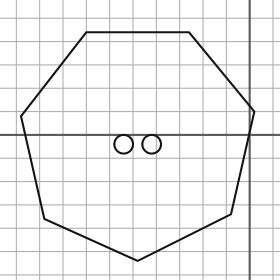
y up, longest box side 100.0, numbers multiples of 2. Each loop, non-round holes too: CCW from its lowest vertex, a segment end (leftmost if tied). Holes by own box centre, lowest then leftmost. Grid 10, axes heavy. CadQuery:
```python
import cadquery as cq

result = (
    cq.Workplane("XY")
    .moveTo(-48.0, -54.0)
    .lineTo(-8.0, -34.0)
    .lineTo(2.0, 10.0)
    .lineTo(-26.0, 44.0)
    .lineTo(-70.0, 44.0)
    .lineTo(-98.0, 8.0)
    .lineTo(-88.0, -36.0)
    .close()
    .moveTo(-54.0, -4.0)
    .circle(4.0)
    .moveTo(-42.0, -4.0)
    .circle(4.0)
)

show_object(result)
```